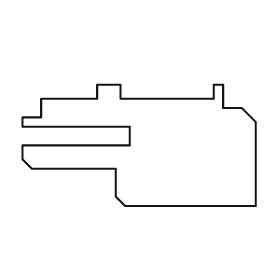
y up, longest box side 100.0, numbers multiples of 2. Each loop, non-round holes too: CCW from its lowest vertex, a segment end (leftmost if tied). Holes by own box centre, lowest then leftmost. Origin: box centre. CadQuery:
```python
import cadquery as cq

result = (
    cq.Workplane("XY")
    .moveTo(-6.0, -26.0)
    .lineTo(50.0, -26.0)
    .lineTo(50.0, 10.0)
    .lineTo(44.0, 16.0)
    .lineTo(36.0, 16.0)
    .lineTo(36.0, 26.0)
    .lineTo(32.0, 26.0)
    .lineTo(32.0, 20.0)
    .lineTo(-8.0, 20.0)
    .lineTo(-8.0, 26.0)
    .lineTo(-18.0, 26.0)
    .lineTo(-18.0, 20.0)
    .lineTo(-42.0, 20.0)
    .lineTo(-42.0, 12.0)
    .lineTo(-50.0, 12.0)
    .lineTo(-50.0, 8.0)
    .lineTo(-4.0, 8.0)
    .lineTo(-4.0, 0.0)
    .lineTo(-50.0, 0.0)
    .lineTo(-50.0, -6.0)
    .lineTo(-46.0, -10.0)
    .lineTo(-10.0, -10.0)
    .lineTo(-10.0, -22.0)
    .close()
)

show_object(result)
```